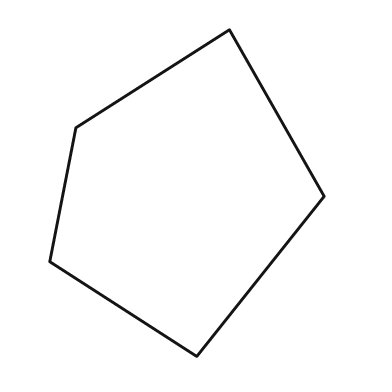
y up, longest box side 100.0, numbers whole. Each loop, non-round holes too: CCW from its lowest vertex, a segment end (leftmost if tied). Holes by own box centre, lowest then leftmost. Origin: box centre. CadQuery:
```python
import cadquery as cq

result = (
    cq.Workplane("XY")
    .moveTo(3.0, -50.0)
    .lineTo(42.0, -1.0)
    .lineTo(13.0, 50.0)
    .lineTo(-34.0, 20.0)
    .lineTo(-42.0, -21.0)
    .close()
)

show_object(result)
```